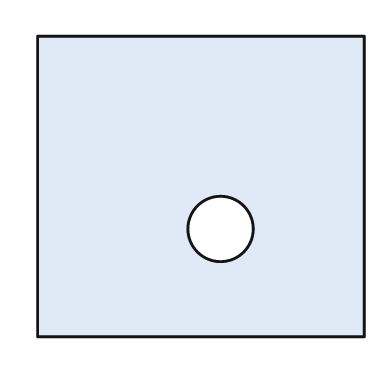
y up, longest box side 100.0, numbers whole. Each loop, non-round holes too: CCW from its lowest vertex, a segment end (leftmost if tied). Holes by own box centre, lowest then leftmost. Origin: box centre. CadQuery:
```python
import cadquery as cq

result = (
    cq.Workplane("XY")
    .moveTo(-50.0, -46.0)
    .lineTo(50.0, -46.0)
    .lineTo(50.0, 46.0)
    .lineTo(-50.0, 46.0)
    .close()
    .moveTo(6.0, -13.0)
    .circle(10.0)
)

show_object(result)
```